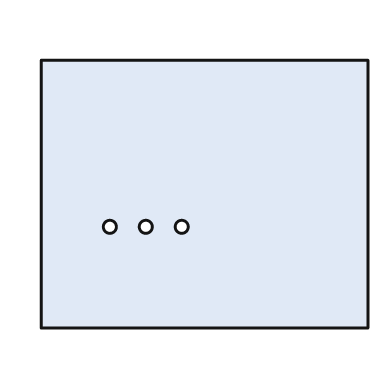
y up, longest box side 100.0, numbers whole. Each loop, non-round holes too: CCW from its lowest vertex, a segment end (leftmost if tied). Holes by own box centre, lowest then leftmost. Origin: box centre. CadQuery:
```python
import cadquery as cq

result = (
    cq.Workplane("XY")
    .moveTo(-50.0, -41.0)
    .lineTo(50.0, -41.0)
    .lineTo(50.0, 41.0)
    .lineTo(-50.0, 41.0)
    .close()
    .moveTo(-29.0, -10.0)
    .circle(2.0)
    .moveTo(-18.0, -10.0)
    .circle(2.0)
    .moveTo(-7.0, -10.0)
    .circle(2.0)
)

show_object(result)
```